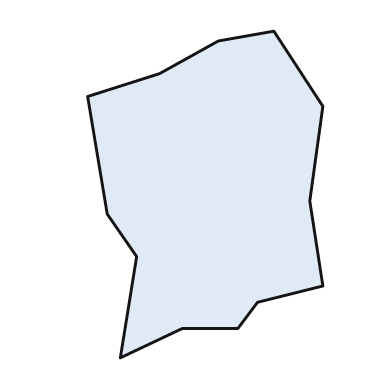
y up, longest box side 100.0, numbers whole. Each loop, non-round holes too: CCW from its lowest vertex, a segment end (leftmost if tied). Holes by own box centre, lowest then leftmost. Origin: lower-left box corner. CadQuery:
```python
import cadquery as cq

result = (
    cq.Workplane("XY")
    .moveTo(10.0, 0.0)
    .lineTo(29.0, 9.0)
    .lineTo(46.0, 9.0)
    .lineTo(52.0, 17.0)
    .lineTo(72.0, 22.0)
    .lineTo(68.0, 48.0)
    .lineTo(72.0, 77.0)
    .lineTo(57.0, 100.0)
    .lineTo(40.0, 97.0)
    .lineTo(22.0, 87.0)
    .lineTo(0.0, 80.0)
    .lineTo(6.0, 44.0)
    .lineTo(15.0, 31.0)
    .close()
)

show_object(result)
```